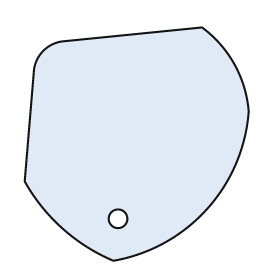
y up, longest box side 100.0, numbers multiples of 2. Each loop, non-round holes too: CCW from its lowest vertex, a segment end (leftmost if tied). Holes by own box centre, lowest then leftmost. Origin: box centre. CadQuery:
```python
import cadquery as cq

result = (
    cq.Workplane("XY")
    .moveTo(-10.0, -50.0)
    .threePointArc((30.0, -28.0), (48.0, 14.0))
    .threePointArc((42.0, 34.0), (28.0, 50.0))
    .lineTo(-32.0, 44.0)
    .threePointArc((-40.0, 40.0), (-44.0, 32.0))
    .lineTo(-48.0, -16.0)
    .threePointArc((-32.0, -36.0), (-10.0, -50.0))
    .close()
    .moveTo(-8.0, -32.0)
    .circle(4.0)
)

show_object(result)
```